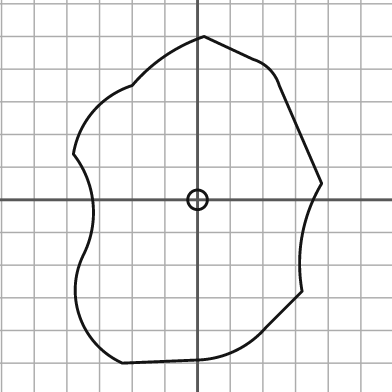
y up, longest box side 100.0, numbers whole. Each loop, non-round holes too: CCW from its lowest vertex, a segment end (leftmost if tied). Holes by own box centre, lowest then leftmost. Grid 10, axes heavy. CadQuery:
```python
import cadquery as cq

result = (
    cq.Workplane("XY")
    .moveTo(-23.0, -50.0)
    .lineTo(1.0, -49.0)
    .threePointArc((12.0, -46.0), (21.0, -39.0))
    .lineTo(32.0, -28.0)
    .threePointArc((32.0, -11.0), (38.0, 5.0))
    .lineTo(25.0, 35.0)
    .threePointArc((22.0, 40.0), (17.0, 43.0))
    .lineTo(2.0, 50.0)
    .threePointArc((-10.0, 44.0), (-20.0, 35.0))
    .threePointArc((-32.0, 27.0), (-38.0, 14.0))
    .threePointArc((-32.0, -1.0), (-35.0, -17.0))
    .threePointArc((-36.0, -36.0), (-23.0, -50.0))
    .close()
    .moveTo(0.0, 0.0)
    .circle(3.0)
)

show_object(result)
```